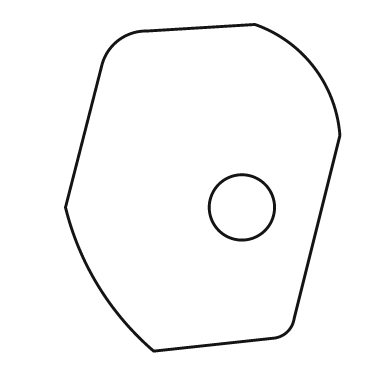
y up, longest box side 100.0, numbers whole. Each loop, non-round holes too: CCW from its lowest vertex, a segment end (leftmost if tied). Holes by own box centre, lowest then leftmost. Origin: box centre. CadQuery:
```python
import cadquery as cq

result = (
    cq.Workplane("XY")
    .moveTo(-15.0, -50.0)
    .lineTo(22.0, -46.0)
    .threePointArc((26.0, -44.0), (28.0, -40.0))
    .lineTo(42.0, 16.0)
    .threePointArc((34.0, 37.0), (16.0, 50.0))
    .lineTo(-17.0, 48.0)
    .threePointArc((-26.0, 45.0), (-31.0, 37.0))
    .lineTo(-42.0, -6.0)
    .threePointArc((-32.0, -30.0), (-15.0, -50.0))
    .close()
    .moveTo(12.0, -6.0)
    .circle(10.0)
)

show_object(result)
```